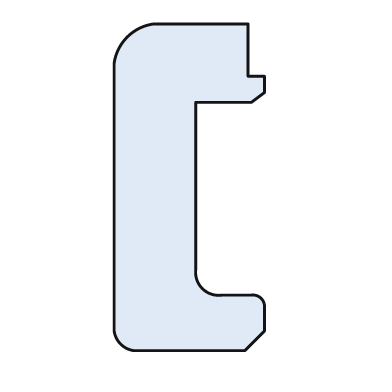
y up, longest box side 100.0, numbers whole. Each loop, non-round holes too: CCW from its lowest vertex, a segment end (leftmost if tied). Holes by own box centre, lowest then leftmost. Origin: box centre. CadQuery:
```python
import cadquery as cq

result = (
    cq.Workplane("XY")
    .moveTo(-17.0, -50.0)
    .lineTo(17.0, -50.0)
    .lineTo(23.0, -44.0)
    .lineTo(23.0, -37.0)
    .threePointArc((22.0, -34.0), (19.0, -33.0))
    .lineTo(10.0, -33.0)
    .threePointArc((4.0, -31.0), (2.0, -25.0))
    .lineTo(2.0, 26.0)
    .lineTo(19.0, 26.0)
    .lineTo(23.0, 29.0)
    .lineTo(23.0, 34.0)
    .lineTo(18.0, 34.0)
    .lineTo(18.0, 50.0)
    .lineTo(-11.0, 50.0)
    .threePointArc((-19.0, 46.0), (-23.0, 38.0))
    .lineTo(-23.0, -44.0)
    .threePointArc((-21.0, -48.0), (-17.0, -50.0))
    .close()
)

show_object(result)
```